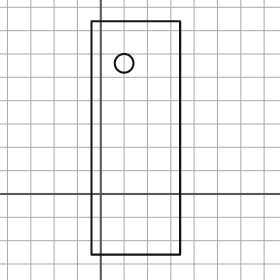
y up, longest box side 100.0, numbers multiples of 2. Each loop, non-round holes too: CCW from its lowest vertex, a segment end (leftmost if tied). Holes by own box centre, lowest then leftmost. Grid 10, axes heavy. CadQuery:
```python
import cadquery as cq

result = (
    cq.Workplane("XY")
    .moveTo(-4.0, -26.0)
    .lineTo(34.0, -26.0)
    .lineTo(34.0, 74.0)
    .lineTo(-4.0, 74.0)
    .close()
    .moveTo(10.0, 56.0)
    .circle(4.0)
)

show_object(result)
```